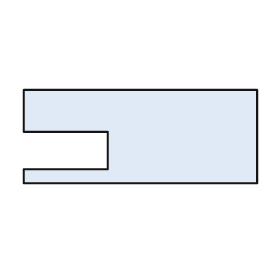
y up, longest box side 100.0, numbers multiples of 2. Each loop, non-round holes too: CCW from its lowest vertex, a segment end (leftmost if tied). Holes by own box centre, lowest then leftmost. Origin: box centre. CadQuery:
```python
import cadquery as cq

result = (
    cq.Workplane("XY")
    .moveTo(-50.0, -20.0)
    .lineTo(50.0, -20.0)
    .lineTo(50.0, 20.0)
    .lineTo(-50.0, 20.0)
    .lineTo(-50.0, 2.0)
    .lineTo(-14.0, 2.0)
    .lineTo(-14.0, -14.0)
    .lineTo(-50.0, -14.0)
    .close()
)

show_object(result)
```